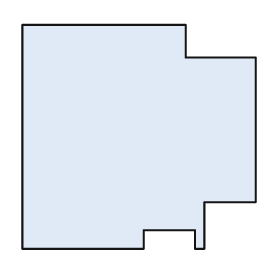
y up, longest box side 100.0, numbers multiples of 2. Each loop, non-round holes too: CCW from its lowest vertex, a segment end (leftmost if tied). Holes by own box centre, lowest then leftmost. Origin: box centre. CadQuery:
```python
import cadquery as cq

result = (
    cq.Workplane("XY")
    .moveTo(-50.0, -48.0)
    .lineTo(2.0, -48.0)
    .lineTo(2.0, -40.0)
    .lineTo(24.0, -40.0)
    .lineTo(24.0, -48.0)
    .lineTo(28.0, -48.0)
    .lineTo(28.0, -28.0)
    .lineTo(50.0, -28.0)
    .lineTo(50.0, 34.0)
    .lineTo(20.0, 34.0)
    .lineTo(20.0, 48.0)
    .lineTo(-50.0, 48.0)
    .close()
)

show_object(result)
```